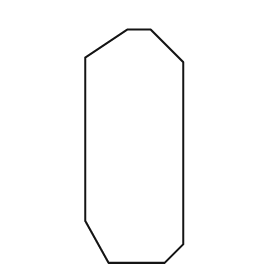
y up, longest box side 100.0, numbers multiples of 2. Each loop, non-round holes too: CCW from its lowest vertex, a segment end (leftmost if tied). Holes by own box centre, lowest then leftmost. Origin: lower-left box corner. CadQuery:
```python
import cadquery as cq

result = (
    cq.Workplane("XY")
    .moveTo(10.0, 0.0)
    .lineTo(34.0, 0.0)
    .lineTo(42.0, 8.0)
    .lineTo(42.0, 86.0)
    .lineTo(28.0, 100.0)
    .lineTo(18.0, 100.0)
    .lineTo(0.0, 88.0)
    .lineTo(0.0, 18.0)
    .close()
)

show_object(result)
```